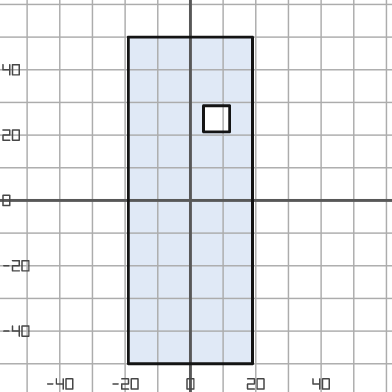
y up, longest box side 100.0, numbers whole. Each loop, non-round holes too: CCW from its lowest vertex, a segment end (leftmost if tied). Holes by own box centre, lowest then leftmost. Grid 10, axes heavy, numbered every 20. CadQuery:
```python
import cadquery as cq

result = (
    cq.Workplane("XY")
    .moveTo(-19.0, -50.0)
    .lineTo(19.0, -50.0)
    .lineTo(19.0, 50.0)
    .lineTo(-19.0, 50.0)
    .close()
    .moveTo(4.0, 21.0)
    .lineTo(12.0, 21.0)
    .lineTo(12.0, 29.0)
    .lineTo(4.0, 29.0)
    .close()
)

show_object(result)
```